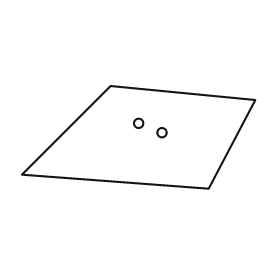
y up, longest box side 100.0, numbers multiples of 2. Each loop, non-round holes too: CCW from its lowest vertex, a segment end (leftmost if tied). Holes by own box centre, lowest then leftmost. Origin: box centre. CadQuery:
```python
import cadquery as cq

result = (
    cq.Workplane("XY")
    .moveTo(30.0, -22.0)
    .lineTo(50.0, 16.0)
    .lineTo(-12.0, 22.0)
    .lineTo(-50.0, -16.0)
    .close()
    .moveTo(10.0, 2.0)
    .circle(2.0)
    .moveTo(0.0, 6.0)
    .circle(2.0)
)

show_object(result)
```